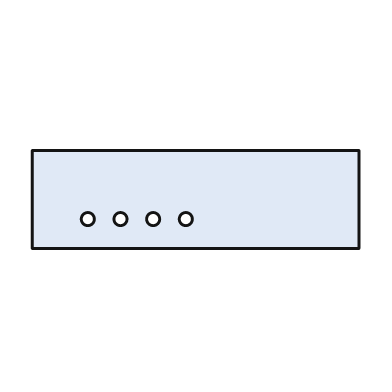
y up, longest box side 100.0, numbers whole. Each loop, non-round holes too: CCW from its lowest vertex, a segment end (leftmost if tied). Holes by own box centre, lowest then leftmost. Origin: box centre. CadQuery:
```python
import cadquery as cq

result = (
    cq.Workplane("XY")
    .moveTo(-50.0, -15.0)
    .lineTo(50.0, -15.0)
    .lineTo(50.0, 15.0)
    .lineTo(-50.0, 15.0)
    .close()
    .moveTo(-33.0, -6.0)
    .circle(2.0)
    .moveTo(-23.0, -6.0)
    .circle(2.0)
    .moveTo(-13.0, -6.0)
    .circle(2.0)
    .moveTo(-3.0, -6.0)
    .circle(2.0)
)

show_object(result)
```